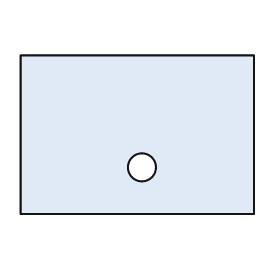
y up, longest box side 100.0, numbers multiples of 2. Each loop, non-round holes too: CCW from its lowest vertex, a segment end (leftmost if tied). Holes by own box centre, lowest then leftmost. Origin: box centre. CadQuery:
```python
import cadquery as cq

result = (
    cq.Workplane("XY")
    .moveTo(-50.0, -34.0)
    .lineTo(50.0, -34.0)
    .lineTo(50.0, 34.0)
    .lineTo(-50.0, 34.0)
    .close()
    .moveTo(2.0, -14.0)
    .circle(6.0)
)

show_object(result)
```